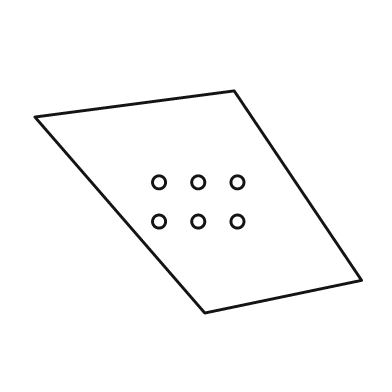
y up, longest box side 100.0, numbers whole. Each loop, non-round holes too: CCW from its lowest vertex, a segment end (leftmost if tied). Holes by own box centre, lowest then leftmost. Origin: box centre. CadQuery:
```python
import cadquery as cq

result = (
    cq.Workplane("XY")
    .moveTo(2.0, -34.0)
    .lineTo(50.0, -24.0)
    .lineTo(11.0, 34.0)
    .lineTo(-50.0, 26.0)
    .close()
    .moveTo(-12.0, -6.0)
    .circle(2.0)
    .moveTo(0.0, -6.0)
    .circle(2.0)
    .moveTo(12.0, -6.0)
    .circle(2.0)
    .moveTo(-12.0, 6.0)
    .circle(2.0)
    .moveTo(0.0, 6.0)
    .circle(2.0)
    .moveTo(12.0, 6.0)
    .circle(2.0)
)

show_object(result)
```